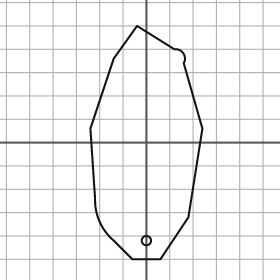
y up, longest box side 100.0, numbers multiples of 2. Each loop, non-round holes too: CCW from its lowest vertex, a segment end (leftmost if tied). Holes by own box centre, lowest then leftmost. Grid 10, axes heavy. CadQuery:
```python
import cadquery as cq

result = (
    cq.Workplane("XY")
    .moveTo(-6.0, -50.0)
    .lineTo(6.0, -50.0)
    .lineTo(18.0, -32.0)
    .lineTo(24.0, 6.0)
    .lineTo(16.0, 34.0)
    .threePointArc((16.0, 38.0), (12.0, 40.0))
    .lineTo(-4.0, 50.0)
    .lineTo(-14.0, 36.0)
    .lineTo(-24.0, 6.0)
    .lineTo(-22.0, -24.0)
    .threePointArc((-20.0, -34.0), (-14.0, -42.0))
    .close()
    .moveTo(0.0, -42.0)
    .circle(2.0)
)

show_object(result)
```